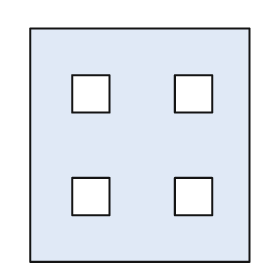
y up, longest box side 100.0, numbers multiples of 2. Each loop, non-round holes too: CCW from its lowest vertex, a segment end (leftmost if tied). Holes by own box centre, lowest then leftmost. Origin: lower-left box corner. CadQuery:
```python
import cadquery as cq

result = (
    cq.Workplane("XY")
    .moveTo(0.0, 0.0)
    .lineTo(94.0, 0.0)
    .lineTo(94.0, 100.0)
    .lineTo(0.0, 100.0)
    .close()
    .moveTo(18.0, 20.0)
    .lineTo(34.0, 20.0)
    .lineTo(34.0, 36.0)
    .lineTo(18.0, 36.0)
    .close()
    .moveTo(62.0, 20.0)
    .lineTo(78.0, 20.0)
    .lineTo(78.0, 36.0)
    .lineTo(62.0, 36.0)
    .close()
    .moveTo(18.0, 64.0)
    .lineTo(34.0, 64.0)
    .lineTo(34.0, 80.0)
    .lineTo(18.0, 80.0)
    .close()
    .moveTo(62.0, 64.0)
    .lineTo(78.0, 64.0)
    .lineTo(78.0, 80.0)
    .lineTo(62.0, 80.0)
    .close()
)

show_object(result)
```